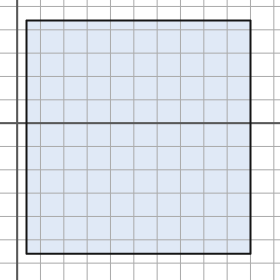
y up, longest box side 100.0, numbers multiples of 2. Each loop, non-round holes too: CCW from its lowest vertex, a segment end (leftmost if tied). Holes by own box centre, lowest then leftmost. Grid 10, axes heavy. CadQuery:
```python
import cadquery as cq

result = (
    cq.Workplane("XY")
    .moveTo(4.0, -56.0)
    .lineTo(100.0, -56.0)
    .lineTo(100.0, 44.0)
    .lineTo(4.0, 44.0)
    .close()
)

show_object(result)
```